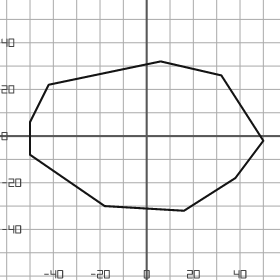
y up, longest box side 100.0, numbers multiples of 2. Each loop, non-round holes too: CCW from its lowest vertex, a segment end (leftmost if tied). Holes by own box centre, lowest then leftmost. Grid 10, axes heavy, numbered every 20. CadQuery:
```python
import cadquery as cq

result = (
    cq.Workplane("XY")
    .moveTo(16.0, -32.0)
    .lineTo(38.0, -18.0)
    .lineTo(50.0, -2.0)
    .lineTo(32.0, 26.0)
    .lineTo(6.0, 32.0)
    .lineTo(-42.0, 22.0)
    .lineTo(-50.0, 6.0)
    .lineTo(-50.0, -8.0)
    .lineTo(-18.0, -30.0)
    .close()
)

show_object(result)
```